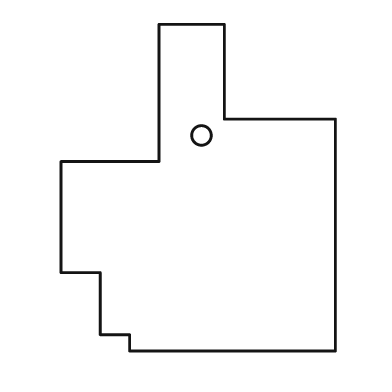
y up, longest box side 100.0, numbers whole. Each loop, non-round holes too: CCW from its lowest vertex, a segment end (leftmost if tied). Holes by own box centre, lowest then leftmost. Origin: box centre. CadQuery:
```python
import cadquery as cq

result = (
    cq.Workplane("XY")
    .moveTo(-21.0, -50.0)
    .lineTo(42.0, -50.0)
    .lineTo(42.0, 21.0)
    .lineTo(8.0, 21.0)
    .lineTo(8.0, 50.0)
    .lineTo(-12.0, 50.0)
    .lineTo(-12.0, 8.0)
    .lineTo(-42.0, 8.0)
    .lineTo(-42.0, -26.0)
    .lineTo(-30.0, -26.0)
    .lineTo(-30.0, -45.0)
    .lineTo(-21.0, -45.0)
    .close()
    .moveTo(1.0, 16.0)
    .circle(3.0)
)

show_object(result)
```